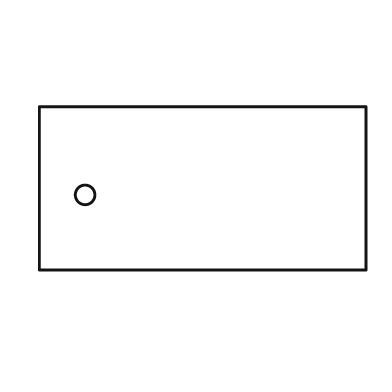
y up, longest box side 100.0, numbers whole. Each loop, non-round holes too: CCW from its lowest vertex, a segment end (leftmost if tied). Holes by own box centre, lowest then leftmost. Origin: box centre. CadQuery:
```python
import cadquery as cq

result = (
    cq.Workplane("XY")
    .moveTo(-50.0, -25.0)
    .lineTo(50.0, -25.0)
    .lineTo(50.0, 25.0)
    .lineTo(-50.0, 25.0)
    .close()
    .moveTo(-36.0, -2.0)
    .circle(3.0)
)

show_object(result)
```